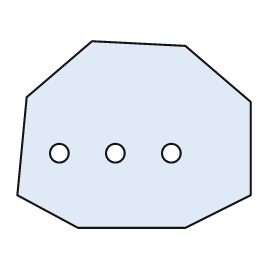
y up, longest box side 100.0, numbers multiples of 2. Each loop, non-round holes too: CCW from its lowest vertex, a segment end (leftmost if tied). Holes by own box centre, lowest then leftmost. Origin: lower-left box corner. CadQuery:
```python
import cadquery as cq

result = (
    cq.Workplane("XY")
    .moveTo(26.0, 0.0)
    .lineTo(72.0, 0.0)
    .lineTo(100.0, 14.0)
    .lineTo(100.0, 54.0)
    .lineTo(72.0, 78.0)
    .lineTo(32.0, 80.0)
    .lineTo(4.0, 56.0)
    .lineTo(0.0, 14.0)
    .close()
    .moveTo(18.0, 32.0)
    .circle(4.0)
    .moveTo(42.0, 32.0)
    .circle(4.0)
    .moveTo(66.0, 32.0)
    .circle(4.0)
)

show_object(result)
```